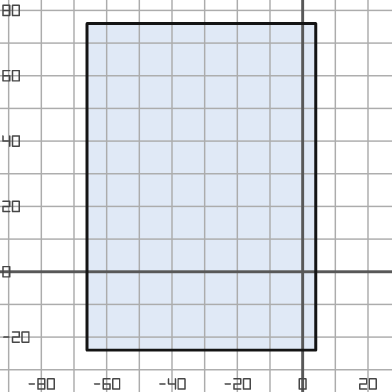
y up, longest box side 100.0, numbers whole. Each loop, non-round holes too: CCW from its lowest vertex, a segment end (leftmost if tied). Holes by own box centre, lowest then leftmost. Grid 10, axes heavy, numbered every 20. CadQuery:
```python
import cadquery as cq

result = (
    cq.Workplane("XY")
    .moveTo(-66.0, -24.0)
    .lineTo(4.0, -24.0)
    .lineTo(4.0, 76.0)
    .lineTo(-66.0, 76.0)
    .close()
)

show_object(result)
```